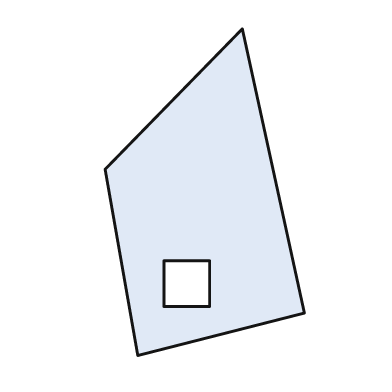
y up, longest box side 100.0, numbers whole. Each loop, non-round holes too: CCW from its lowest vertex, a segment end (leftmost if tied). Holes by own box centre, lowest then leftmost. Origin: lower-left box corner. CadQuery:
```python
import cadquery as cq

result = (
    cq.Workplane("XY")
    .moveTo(10.0, 0.0)
    .lineTo(61.0, 13.0)
    .lineTo(42.0, 100.0)
    .lineTo(0.0, 57.0)
    .close()
    .moveTo(18.0, 15.0)
    .lineTo(32.0, 15.0)
    .lineTo(32.0, 29.0)
    .lineTo(18.0, 29.0)
    .close()
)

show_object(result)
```